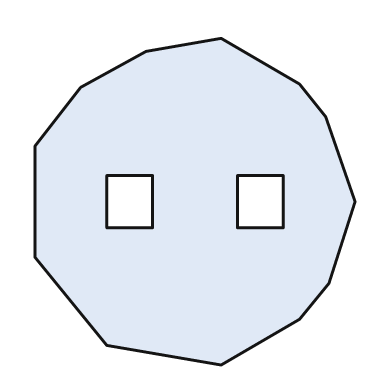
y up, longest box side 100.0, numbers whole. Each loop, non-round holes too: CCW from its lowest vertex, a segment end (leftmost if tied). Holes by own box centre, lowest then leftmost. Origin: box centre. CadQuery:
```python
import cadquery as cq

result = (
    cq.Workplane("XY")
    .moveTo(8.0, -50.0)
    .lineTo(32.0, -36.0)
    .lineTo(41.0, -25.0)
    .lineTo(49.0, 0.0)
    .lineTo(40.0, 26.0)
    .lineTo(32.0, 36.0)
    .lineTo(8.0, 50.0)
    .lineTo(-15.0, 46.0)
    .lineTo(-35.0, 35.0)
    .lineTo(-49.0, 17.0)
    .lineTo(-49.0, -17.0)
    .lineTo(-27.0, -44.0)
    .close()
    .moveTo(-27.0, -8.0)
    .lineTo(-13.0, -8.0)
    .lineTo(-13.0, 8.0)
    .lineTo(-27.0, 8.0)
    .close()
    .moveTo(13.0, -8.0)
    .lineTo(27.0, -8.0)
    .lineTo(27.0, 8.0)
    .lineTo(13.0, 8.0)
    .close()
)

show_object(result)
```